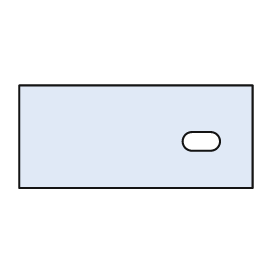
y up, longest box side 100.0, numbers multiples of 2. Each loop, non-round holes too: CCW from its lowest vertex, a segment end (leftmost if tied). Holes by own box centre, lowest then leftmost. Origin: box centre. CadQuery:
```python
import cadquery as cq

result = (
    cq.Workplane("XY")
    .moveTo(-50.0, -22.0)
    .lineTo(50.0, -22.0)
    .lineTo(50.0, 22.0)
    .lineTo(-50.0, 22.0)
    .close()
    .moveTo(24.0, -6.0)
    .lineTo(32.0, -6.0)
    .threePointArc((36.0, -2.0), (32.0, 2.0))
    .lineTo(24.0, 2.0)
    .threePointArc((20.0, -2.0), (24.0, -6.0))
    .close()
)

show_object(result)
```